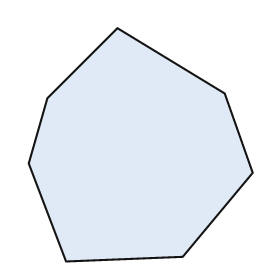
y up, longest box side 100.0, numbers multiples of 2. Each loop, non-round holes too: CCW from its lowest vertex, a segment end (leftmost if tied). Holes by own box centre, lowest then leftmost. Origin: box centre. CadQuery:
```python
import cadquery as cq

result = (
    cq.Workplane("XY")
    .moveTo(-32.0, -50.0)
    .lineTo(18.0, -48.0)
    .lineTo(48.0, -12.0)
    .lineTo(36.0, 22.0)
    .lineTo(-10.0, 50.0)
    .lineTo(-40.0, 20.0)
    .lineTo(-48.0, -8.0)
    .close()
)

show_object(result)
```